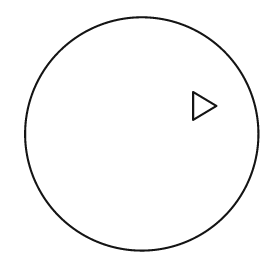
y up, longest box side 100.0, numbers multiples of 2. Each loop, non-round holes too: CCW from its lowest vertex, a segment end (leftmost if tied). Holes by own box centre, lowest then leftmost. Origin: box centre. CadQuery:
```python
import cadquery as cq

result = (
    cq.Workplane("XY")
    .moveTo(0.0, 0.0)
    .circle(50.0)
    .moveTo(22.0, 6.0)
    .lineTo(32.0, 12.0)
    .lineTo(22.0, 18.0)
    .close()
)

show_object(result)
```